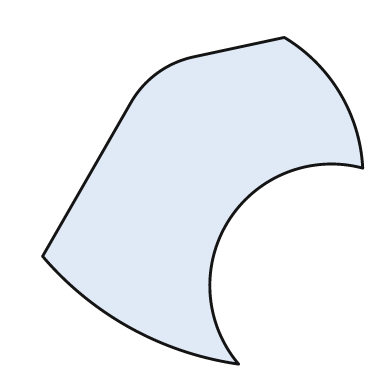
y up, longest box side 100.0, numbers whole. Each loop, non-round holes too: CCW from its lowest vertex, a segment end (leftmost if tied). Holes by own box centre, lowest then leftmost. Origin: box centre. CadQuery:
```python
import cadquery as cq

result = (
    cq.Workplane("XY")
    .moveTo(11.0, -50.0)
    .threePointArc((8.0, -6.0), (49.0, 10.0))
    .threePointArc((42.0, 33.0), (25.0, 50.0))
    .lineTo(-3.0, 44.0)
    .threePointArc((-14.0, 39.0), (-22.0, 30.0))
    .lineTo(-49.0, -17.0)
    .threePointArc((-22.0, -39.0), (11.0, -50.0))
    .close()
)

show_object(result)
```